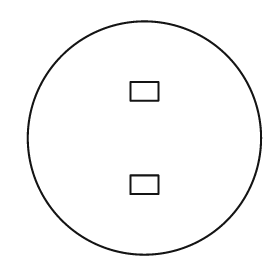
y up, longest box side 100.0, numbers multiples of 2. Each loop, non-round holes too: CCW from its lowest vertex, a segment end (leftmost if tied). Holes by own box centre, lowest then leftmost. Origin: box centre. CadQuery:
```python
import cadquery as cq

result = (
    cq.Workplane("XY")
    .moveTo(0.0, 0.0)
    .circle(50.0)
    .moveTo(-6.0, -24.0)
    .lineTo(6.0, -24.0)
    .lineTo(6.0, -16.0)
    .lineTo(-6.0, -16.0)
    .close()
    .moveTo(-6.0, 16.0)
    .lineTo(6.0, 16.0)
    .lineTo(6.0, 24.0)
    .lineTo(-6.0, 24.0)
    .close()
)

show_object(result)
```